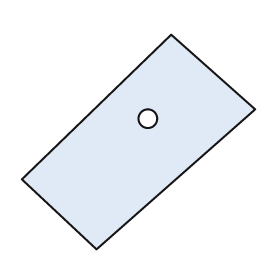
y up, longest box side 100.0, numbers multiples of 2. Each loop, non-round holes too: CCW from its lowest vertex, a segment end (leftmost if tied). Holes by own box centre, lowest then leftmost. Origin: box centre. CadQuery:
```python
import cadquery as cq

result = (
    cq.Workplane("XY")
    .moveTo(-18.0, -46.0)
    .lineTo(50.0, 14.0)
    .lineTo(14.0, 46.0)
    .lineTo(-50.0, -16.0)
    .close()
    .moveTo(4.0, 10.0)
    .circle(4.0)
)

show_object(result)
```